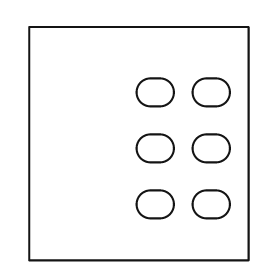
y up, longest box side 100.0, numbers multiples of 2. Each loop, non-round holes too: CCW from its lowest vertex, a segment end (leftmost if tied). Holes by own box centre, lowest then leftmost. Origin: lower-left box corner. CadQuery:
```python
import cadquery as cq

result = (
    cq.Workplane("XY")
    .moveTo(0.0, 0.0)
    .lineTo(94.0, 0.0)
    .lineTo(94.0, 100.0)
    .lineTo(0.0, 100.0)
    .close()
    .moveTo(52.0, 18.0)
    .lineTo(56.0, 18.0)
    .threePointArc((62.0, 24.0), (56.0, 30.0))
    .lineTo(52.0, 30.0)
    .threePointArc((46.0, 24.0), (52.0, 18.0))
    .close()
    .moveTo(76.0, 18.0)
    .lineTo(80.0, 18.0)
    .threePointArc((86.0, 24.0), (80.0, 30.0))
    .lineTo(76.0, 30.0)
    .threePointArc((70.0, 24.0), (76.0, 18.0))
    .close()
    .moveTo(52.0, 42.0)
    .lineTo(56.0, 42.0)
    .threePointArc((62.0, 48.0), (56.0, 54.0))
    .lineTo(52.0, 54.0)
    .threePointArc((46.0, 48.0), (52.0, 42.0))
    .close()
    .moveTo(76.0, 42.0)
    .lineTo(80.0, 42.0)
    .threePointArc((86.0, 48.0), (80.0, 54.0))
    .lineTo(76.0, 54.0)
    .threePointArc((70.0, 48.0), (76.0, 42.0))
    .close()
    .moveTo(52.0, 66.0)
    .lineTo(56.0, 66.0)
    .threePointArc((62.0, 72.0), (56.0, 78.0))
    .lineTo(52.0, 78.0)
    .threePointArc((46.0, 72.0), (52.0, 66.0))
    .close()
    .moveTo(76.0, 66.0)
    .lineTo(80.0, 66.0)
    .threePointArc((86.0, 72.0), (80.0, 78.0))
    .lineTo(76.0, 78.0)
    .threePointArc((70.0, 72.0), (76.0, 66.0))
    .close()
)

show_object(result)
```